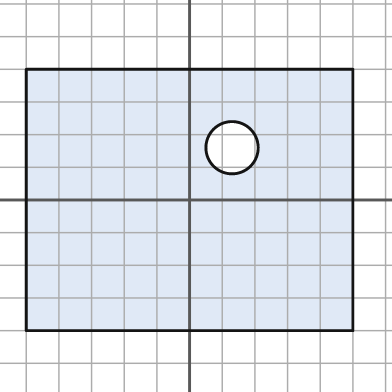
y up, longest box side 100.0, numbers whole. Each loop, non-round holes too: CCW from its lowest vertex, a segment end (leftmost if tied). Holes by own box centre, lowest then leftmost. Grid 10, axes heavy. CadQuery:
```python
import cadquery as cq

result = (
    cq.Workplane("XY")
    .moveTo(-50.0, -40.0)
    .lineTo(50.0, -40.0)
    .lineTo(50.0, 40.0)
    .lineTo(-50.0, 40.0)
    .close()
    .moveTo(13.0, 16.0)
    .circle(8.0)
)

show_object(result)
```